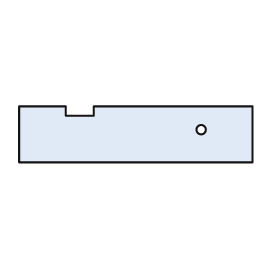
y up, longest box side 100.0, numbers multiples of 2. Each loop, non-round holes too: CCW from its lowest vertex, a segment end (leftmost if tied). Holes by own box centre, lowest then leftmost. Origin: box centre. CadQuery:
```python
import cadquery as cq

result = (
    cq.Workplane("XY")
    .moveTo(-50.0, -12.0)
    .lineTo(50.0, -12.0)
    .lineTo(50.0, 12.0)
    .lineTo(-18.0, 12.0)
    .lineTo(-18.0, 8.0)
    .lineTo(-30.0, 8.0)
    .lineTo(-30.0, 12.0)
    .lineTo(-50.0, 12.0)
    .close()
    .moveTo(28.0, 2.0)
    .circle(2.0)
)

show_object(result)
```